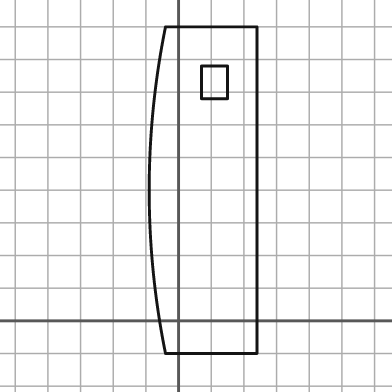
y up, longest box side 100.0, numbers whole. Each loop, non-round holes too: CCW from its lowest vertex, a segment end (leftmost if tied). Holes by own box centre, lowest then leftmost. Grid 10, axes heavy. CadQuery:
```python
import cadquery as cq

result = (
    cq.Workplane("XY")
    .moveTo(-4.0, -10.0)
    .lineTo(24.0, -10.0)
    .lineTo(24.0, 90.0)
    .lineTo(-4.0, 90.0)
    .threePointArc((-9.0, 40.0), (-4.0, -10.0))
    .close()
    .moveTo(7.0, 68.0)
    .lineTo(15.0, 68.0)
    .lineTo(15.0, 78.0)
    .lineTo(7.0, 78.0)
    .close()
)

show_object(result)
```